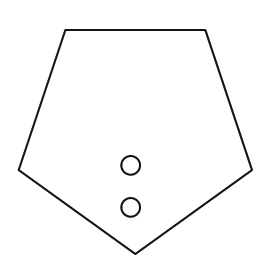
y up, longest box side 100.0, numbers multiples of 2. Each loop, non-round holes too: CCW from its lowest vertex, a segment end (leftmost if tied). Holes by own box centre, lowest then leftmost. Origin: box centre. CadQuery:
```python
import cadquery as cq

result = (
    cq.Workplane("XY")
    .moveTo(0.0, -48.0)
    .lineTo(50.0, -12.0)
    .lineTo(30.0, 48.0)
    .lineTo(-30.0, 48.0)
    .lineTo(-50.0, -12.0)
    .close()
    .moveTo(-2.0, -28.0)
    .circle(4.0)
    .moveTo(-2.0, -10.0)
    .circle(4.0)
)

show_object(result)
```